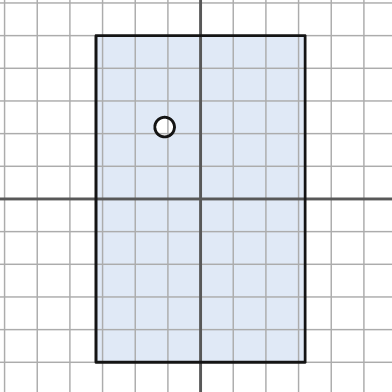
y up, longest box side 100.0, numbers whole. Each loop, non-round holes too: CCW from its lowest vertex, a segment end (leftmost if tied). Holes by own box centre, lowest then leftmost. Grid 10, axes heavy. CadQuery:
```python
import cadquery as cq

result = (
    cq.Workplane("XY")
    .moveTo(-32.0, -50.0)
    .lineTo(32.0, -50.0)
    .lineTo(32.0, 50.0)
    .lineTo(-32.0, 50.0)
    .close()
    .moveTo(-11.0, 22.0)
    .circle(3.0)
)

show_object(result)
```